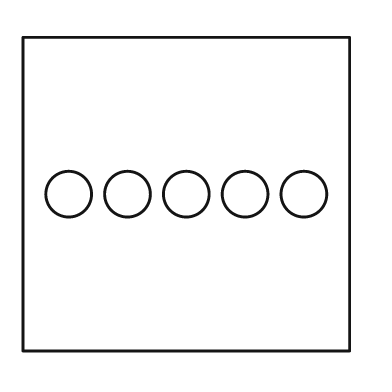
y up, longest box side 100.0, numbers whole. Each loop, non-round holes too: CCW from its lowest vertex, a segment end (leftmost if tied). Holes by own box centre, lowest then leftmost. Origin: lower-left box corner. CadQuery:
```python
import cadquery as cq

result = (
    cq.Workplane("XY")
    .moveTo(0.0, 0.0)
    .lineTo(100.0, 0.0)
    .lineTo(100.0, 96.0)
    .lineTo(0.0, 96.0)
    .close()
    .moveTo(14.0, 48.0)
    .circle(7.0)
    .moveTo(32.0, 48.0)
    .circle(7.0)
    .moveTo(50.0, 48.0)
    .circle(7.0)
    .moveTo(68.0, 48.0)
    .circle(7.0)
    .moveTo(86.0, 48.0)
    .circle(7.0)
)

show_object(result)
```